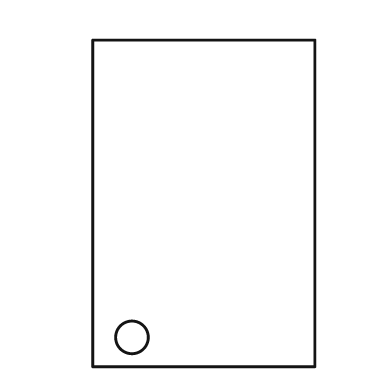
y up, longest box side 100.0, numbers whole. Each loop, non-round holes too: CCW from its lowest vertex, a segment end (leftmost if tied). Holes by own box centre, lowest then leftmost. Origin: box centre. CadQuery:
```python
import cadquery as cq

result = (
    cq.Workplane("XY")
    .moveTo(-34.0, -50.0)
    .lineTo(34.0, -50.0)
    .lineTo(34.0, 50.0)
    .lineTo(-34.0, 50.0)
    .close()
    .moveTo(-22.0, -41.0)
    .circle(5.0)
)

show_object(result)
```